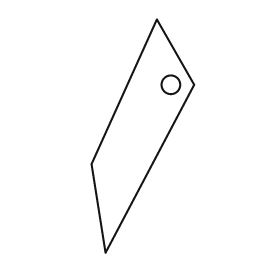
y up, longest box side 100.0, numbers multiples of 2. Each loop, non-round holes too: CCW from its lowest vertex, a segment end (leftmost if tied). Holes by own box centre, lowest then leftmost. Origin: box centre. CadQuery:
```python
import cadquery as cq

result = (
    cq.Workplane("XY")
    .moveTo(-16.0, -50.0)
    .lineTo(22.0, 22.0)
    .lineTo(6.0, 50.0)
    .lineTo(-22.0, -12.0)
    .close()
    .moveTo(12.0, 22.0)
    .circle(4.0)
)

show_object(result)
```